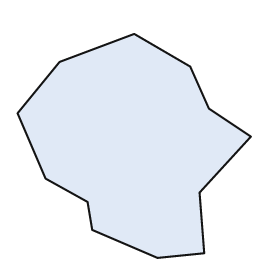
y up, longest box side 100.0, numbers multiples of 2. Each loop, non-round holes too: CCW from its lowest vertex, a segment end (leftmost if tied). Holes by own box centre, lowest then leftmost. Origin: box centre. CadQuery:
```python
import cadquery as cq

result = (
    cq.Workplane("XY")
    .moveTo(10.0, -48.0)
    .lineTo(30.0, -46.0)
    .lineTo(28.0, -20.0)
    .lineTo(50.0, 4.0)
    .lineTo(32.0, 16.0)
    .lineTo(24.0, 34.0)
    .lineTo(0.0, 48.0)
    .lineTo(-32.0, 36.0)
    .lineTo(-50.0, 14.0)
    .lineTo(-38.0, -14.0)
    .lineTo(-20.0, -24.0)
    .lineTo(-18.0, -36.0)
    .close()
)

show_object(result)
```